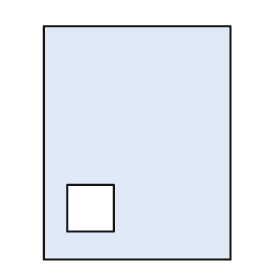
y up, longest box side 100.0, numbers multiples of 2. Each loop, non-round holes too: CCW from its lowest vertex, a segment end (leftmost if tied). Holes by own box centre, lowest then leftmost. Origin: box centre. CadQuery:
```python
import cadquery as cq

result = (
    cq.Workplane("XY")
    .moveTo(-40.0, -50.0)
    .lineTo(40.0, -50.0)
    .lineTo(40.0, 50.0)
    .lineTo(-40.0, 50.0)
    .close()
    .moveTo(-30.0, -38.0)
    .lineTo(-10.0, -38.0)
    .lineTo(-10.0, -18.0)
    .lineTo(-30.0, -18.0)
    .close()
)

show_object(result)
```